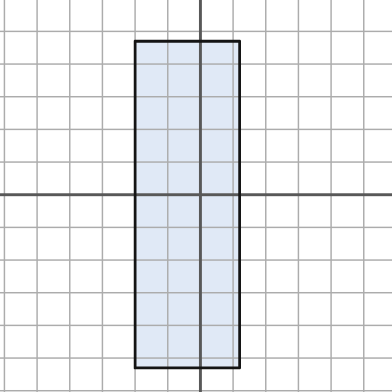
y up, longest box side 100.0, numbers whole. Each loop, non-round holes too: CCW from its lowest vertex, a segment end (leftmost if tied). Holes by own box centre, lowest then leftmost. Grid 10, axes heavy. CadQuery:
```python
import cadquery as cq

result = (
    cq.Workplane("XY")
    .moveTo(-20.0, -53.0)
    .lineTo(12.0, -53.0)
    .lineTo(12.0, 47.0)
    .lineTo(-20.0, 47.0)
    .close()
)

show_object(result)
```